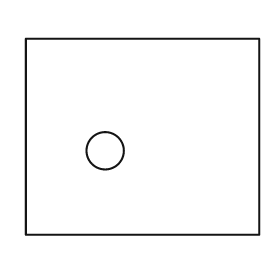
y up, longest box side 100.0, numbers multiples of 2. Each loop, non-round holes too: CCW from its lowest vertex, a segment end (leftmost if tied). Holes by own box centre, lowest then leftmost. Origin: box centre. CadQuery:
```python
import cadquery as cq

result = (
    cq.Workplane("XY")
    .moveTo(-50.0, -42.0)
    .lineTo(50.0, -42.0)
    .lineTo(50.0, 42.0)
    .lineTo(-50.0, 42.0)
    .close()
    .moveTo(-16.0, -6.0)
    .circle(8.0)
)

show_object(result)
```